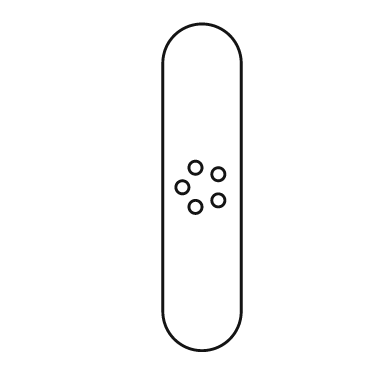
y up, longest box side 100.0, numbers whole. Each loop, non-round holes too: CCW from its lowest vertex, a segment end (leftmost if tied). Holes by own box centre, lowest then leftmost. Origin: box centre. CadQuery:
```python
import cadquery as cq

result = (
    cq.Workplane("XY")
    .moveTo(-12.0, -38.0)
    .threePointArc((0.0, -50.0), (12.0, -38.0))
    .lineTo(12.0, 38.0)
    .threePointArc((0.0, 50.0), (-12.0, 38.0))
    .close()
    .moveTo(-2.0, -6.0)
    .circle(2.0)
    .moveTo(5.0, -4.0)
    .circle(2.0)
    .moveTo(-6.0, 0.0)
    .circle(2.0)
    .moveTo(5.0, 4.0)
    .circle(2.0)
    .moveTo(-2.0, 6.0)
    .circle(2.0)
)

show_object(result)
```